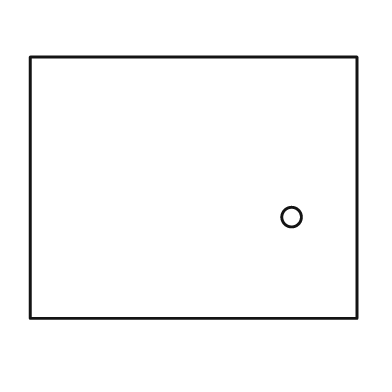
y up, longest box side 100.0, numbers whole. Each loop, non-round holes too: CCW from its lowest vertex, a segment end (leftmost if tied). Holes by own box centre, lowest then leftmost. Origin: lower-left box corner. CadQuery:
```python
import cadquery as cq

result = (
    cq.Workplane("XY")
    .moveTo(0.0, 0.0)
    .lineTo(100.0, 0.0)
    .lineTo(100.0, 80.0)
    .lineTo(0.0, 80.0)
    .close()
    .moveTo(80.0, 31.0)
    .circle(3.0)
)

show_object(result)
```